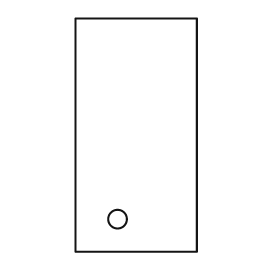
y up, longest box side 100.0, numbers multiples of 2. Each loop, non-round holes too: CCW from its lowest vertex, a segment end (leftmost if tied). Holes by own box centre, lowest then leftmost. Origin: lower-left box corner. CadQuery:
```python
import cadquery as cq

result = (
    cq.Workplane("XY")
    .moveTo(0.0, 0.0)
    .lineTo(52.0, 0.0)
    .lineTo(52.0, 100.0)
    .lineTo(0.0, 100.0)
    .close()
    .moveTo(18.0, 14.0)
    .circle(4.0)
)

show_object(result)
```